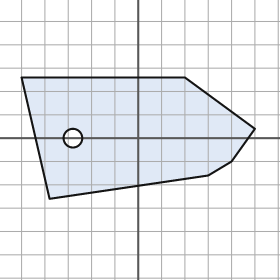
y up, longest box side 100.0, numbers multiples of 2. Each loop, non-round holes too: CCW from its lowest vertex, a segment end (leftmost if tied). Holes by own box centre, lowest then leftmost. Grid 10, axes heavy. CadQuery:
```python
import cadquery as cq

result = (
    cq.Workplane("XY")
    .moveTo(-38.0, -26.0)
    .lineTo(30.0, -16.0)
    .lineTo(40.0, -10.0)
    .lineTo(50.0, 4.0)
    .lineTo(20.0, 26.0)
    .lineTo(-50.0, 26.0)
    .close()
    .moveTo(-28.0, 0.0)
    .circle(4.0)
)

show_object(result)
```